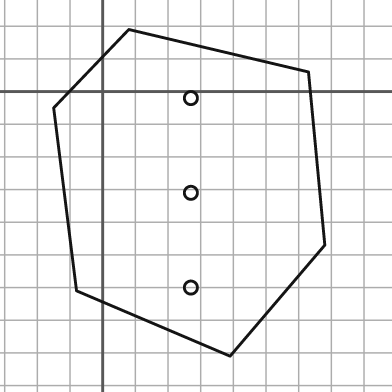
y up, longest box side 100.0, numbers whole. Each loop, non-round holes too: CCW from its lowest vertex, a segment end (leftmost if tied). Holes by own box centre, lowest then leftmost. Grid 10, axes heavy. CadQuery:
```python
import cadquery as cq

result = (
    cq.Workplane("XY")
    .moveTo(39.0, -81.0)
    .lineTo(68.0, -47.0)
    .lineTo(63.0, 6.0)
    .lineTo(8.0, 19.0)
    .lineTo(-15.0, -5.0)
    .lineTo(-8.0, -61.0)
    .close()
    .moveTo(27.0, -60.0)
    .circle(2.0)
    .moveTo(27.0, -31.0)
    .circle(2.0)
    .moveTo(27.0, -2.0)
    .circle(2.0)
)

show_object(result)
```